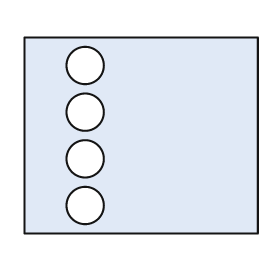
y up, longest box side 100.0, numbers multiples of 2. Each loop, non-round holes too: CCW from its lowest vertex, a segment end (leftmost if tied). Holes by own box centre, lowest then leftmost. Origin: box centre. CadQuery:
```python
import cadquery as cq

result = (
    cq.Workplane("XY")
    .moveTo(-50.0, -42.0)
    .lineTo(50.0, -42.0)
    .lineTo(50.0, 42.0)
    .lineTo(-50.0, 42.0)
    .close()
    .moveTo(-24.0, -30.0)
    .circle(8.0)
    .moveTo(-24.0, -10.0)
    .circle(8.0)
    .moveTo(-24.0, 10.0)
    .circle(8.0)
    .moveTo(-24.0, 30.0)
    .circle(8.0)
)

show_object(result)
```